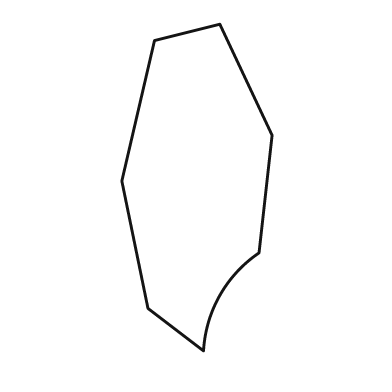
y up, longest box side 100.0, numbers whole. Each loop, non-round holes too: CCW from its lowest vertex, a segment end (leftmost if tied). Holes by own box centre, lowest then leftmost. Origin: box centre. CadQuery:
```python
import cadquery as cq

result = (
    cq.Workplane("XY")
    .moveTo(2.0, -50.0)
    .threePointArc((7.0, -33.0), (19.0, -20.0))
    .lineTo(23.0, 16.0)
    .lineTo(7.0, 50.0)
    .lineTo(-13.0, 45.0)
    .lineTo(-23.0, 2.0)
    .lineTo(-15.0, -37.0)
    .close()
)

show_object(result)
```